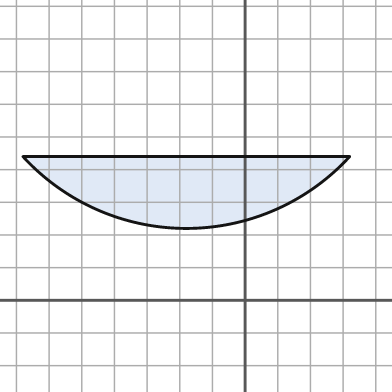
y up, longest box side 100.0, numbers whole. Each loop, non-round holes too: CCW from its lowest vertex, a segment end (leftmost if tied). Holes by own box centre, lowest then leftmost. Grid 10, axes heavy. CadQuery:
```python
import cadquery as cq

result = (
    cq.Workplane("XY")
    .moveTo(-68.0, 44.0)
    .threePointArc((-18.0, 22.0), (32.0, 44.0))
    .close()
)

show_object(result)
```